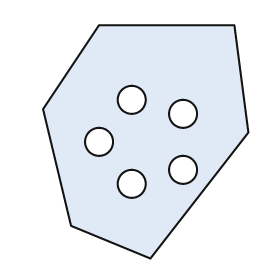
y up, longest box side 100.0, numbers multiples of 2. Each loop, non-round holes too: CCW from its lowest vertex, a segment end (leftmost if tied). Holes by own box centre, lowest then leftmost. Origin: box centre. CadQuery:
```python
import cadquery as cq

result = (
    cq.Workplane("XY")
    .moveTo(2.0, -50.0)
    .lineTo(44.0, 4.0)
    .lineTo(38.0, 50.0)
    .lineTo(-20.0, 50.0)
    .lineTo(-44.0, 14.0)
    .lineTo(-32.0, -36.0)
    .close()
    .moveTo(-6.0, -18.0)
    .circle(6.0)
    .moveTo(16.0, -12.0)
    .circle(6.0)
    .moveTo(-20.0, 0.0)
    .circle(6.0)
    .moveTo(16.0, 12.0)
    .circle(6.0)
    .moveTo(-6.0, 18.0)
    .circle(6.0)
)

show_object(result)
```